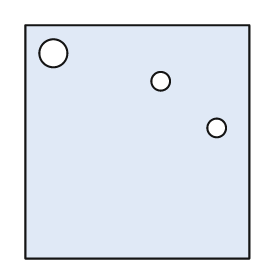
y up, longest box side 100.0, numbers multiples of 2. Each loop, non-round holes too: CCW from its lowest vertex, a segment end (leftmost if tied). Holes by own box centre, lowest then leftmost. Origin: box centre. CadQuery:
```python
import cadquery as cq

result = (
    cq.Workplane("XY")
    .moveTo(-48.0, -50.0)
    .lineTo(48.0, -50.0)
    .lineTo(48.0, 50.0)
    .lineTo(-48.0, 50.0)
    .close()
    .moveTo(34.0, 6.0)
    .circle(4.0)
    .moveTo(10.0, 26.0)
    .circle(4.0)
    .moveTo(-36.0, 38.0)
    .circle(6.0)
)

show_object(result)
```